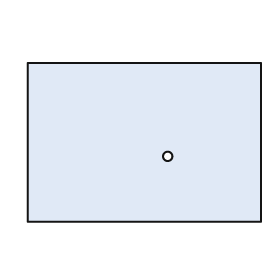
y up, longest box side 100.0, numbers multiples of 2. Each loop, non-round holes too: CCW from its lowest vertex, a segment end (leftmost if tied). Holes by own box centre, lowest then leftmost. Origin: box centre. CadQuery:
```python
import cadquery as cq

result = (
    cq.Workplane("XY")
    .moveTo(-50.0, -34.0)
    .lineTo(50.0, -34.0)
    .lineTo(50.0, 34.0)
    .lineTo(-50.0, 34.0)
    .close()
    .moveTo(10.0, -6.0)
    .circle(2.0)
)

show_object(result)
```